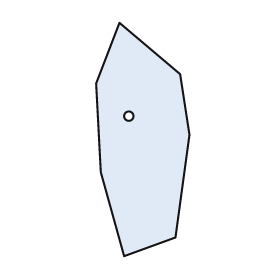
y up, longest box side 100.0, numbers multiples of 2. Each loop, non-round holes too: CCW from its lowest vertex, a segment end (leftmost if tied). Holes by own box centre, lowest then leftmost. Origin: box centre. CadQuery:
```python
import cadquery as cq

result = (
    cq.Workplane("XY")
    .moveTo(-8.0, -50.0)
    .lineTo(14.0, -42.0)
    .lineTo(20.0, 2.0)
    .lineTo(16.0, 28.0)
    .lineTo(-10.0, 50.0)
    .lineTo(-20.0, 24.0)
    .lineTo(-18.0, -14.0)
    .close()
    .moveTo(-6.0, 10.0)
    .circle(2.0)
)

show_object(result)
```